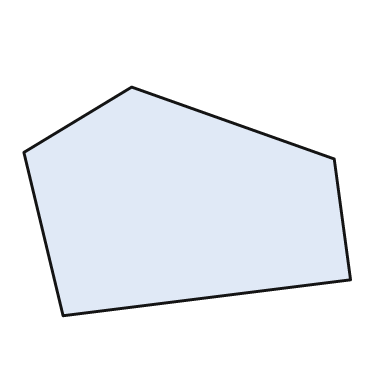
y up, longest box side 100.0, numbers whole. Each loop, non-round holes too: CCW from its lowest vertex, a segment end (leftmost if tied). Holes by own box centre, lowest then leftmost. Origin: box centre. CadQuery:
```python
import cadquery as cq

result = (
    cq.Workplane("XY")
    .moveTo(-38.0, -35.0)
    .lineTo(50.0, -24.0)
    .lineTo(45.0, 13.0)
    .lineTo(-17.0, 35.0)
    .lineTo(-50.0, 15.0)
    .close()
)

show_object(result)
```